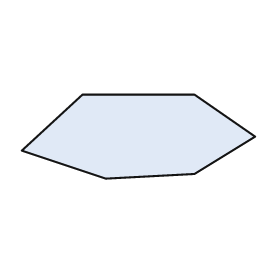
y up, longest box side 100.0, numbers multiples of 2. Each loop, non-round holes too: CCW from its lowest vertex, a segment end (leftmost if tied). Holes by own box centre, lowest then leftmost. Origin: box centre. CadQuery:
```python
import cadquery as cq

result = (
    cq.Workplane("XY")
    .moveTo(-14.0, -18.0)
    .lineTo(24.0, -16.0)
    .lineTo(50.0, 0.0)
    .lineTo(24.0, 18.0)
    .lineTo(-24.0, 18.0)
    .lineTo(-50.0, -6.0)
    .close()
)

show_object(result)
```